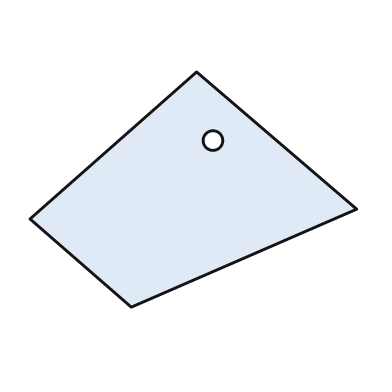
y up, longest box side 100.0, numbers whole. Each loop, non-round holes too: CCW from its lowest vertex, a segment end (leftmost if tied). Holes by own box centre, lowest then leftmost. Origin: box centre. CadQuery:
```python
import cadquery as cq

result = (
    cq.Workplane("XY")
    .moveTo(-19.0, -36.0)
    .lineTo(50.0, -6.0)
    .lineTo(1.0, 36.0)
    .lineTo(-50.0, -9.0)
    .close()
    .moveTo(6.0, 15.0)
    .circle(3.0)
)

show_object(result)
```